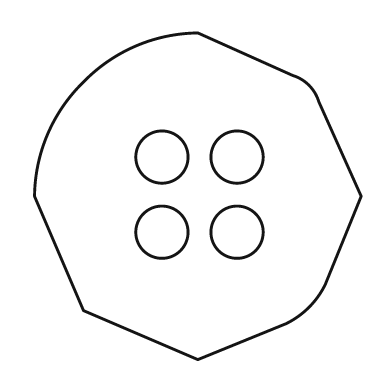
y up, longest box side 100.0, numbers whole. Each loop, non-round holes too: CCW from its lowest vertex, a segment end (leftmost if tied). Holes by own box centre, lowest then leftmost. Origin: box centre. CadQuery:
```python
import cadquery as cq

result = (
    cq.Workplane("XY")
    .moveTo(0.0, -50.0)
    .lineTo(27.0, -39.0)
    .threePointArc((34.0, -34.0), (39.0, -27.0))
    .lineTo(50.0, 0.0)
    .lineTo(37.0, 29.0)
    .threePointArc((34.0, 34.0), (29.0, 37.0))
    .lineTo(0.0, 50.0)
    .threePointArc((-19.0, 46.0), (-35.0, 35.0))
    .threePointArc((-46.0, 19.0), (-50.0, 0.0))
    .lineTo(-35.0, -35.0)
    .close()
    .moveTo(-11.0, -11.0)
    .circle(8.0)
    .moveTo(12.0, -11.0)
    .circle(8.0)
    .moveTo(-11.0, 12.0)
    .circle(8.0)
    .moveTo(12.0, 12.0)
    .circle(8.0)
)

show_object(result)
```